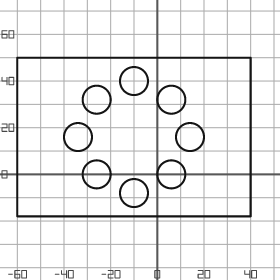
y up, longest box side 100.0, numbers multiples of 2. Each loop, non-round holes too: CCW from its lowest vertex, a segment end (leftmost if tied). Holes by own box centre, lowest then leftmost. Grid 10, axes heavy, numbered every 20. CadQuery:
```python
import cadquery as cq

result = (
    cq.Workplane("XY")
    .moveTo(-60.0, -18.0)
    .lineTo(40.0, -18.0)
    .lineTo(40.0, 50.0)
    .lineTo(-60.0, 50.0)
    .close()
    .moveTo(-10.0, -8.0)
    .circle(6.0)
    .moveTo(-26.0, 0.0)
    .circle(6.0)
    .moveTo(6.0, 0.0)
    .circle(6.0)
    .moveTo(-34.0, 16.0)
    .circle(6.0)
    .moveTo(14.0, 16.0)
    .circle(6.0)
    .moveTo(-26.0, 32.0)
    .circle(6.0)
    .moveTo(6.0, 32.0)
    .circle(6.0)
    .moveTo(-10.0, 40.0)
    .circle(6.0)
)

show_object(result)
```